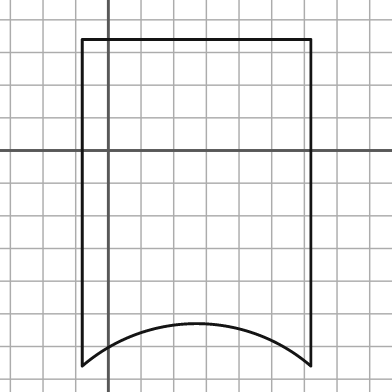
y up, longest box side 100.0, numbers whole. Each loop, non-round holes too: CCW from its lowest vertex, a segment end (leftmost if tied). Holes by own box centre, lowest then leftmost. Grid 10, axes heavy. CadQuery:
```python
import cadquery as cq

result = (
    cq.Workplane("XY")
    .moveTo(-8.0, -66.0)
    .threePointArc((27.0, -53.0), (62.0, -66.0))
    .lineTo(62.0, 34.0)
    .lineTo(-8.0, 34.0)
    .close()
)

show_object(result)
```